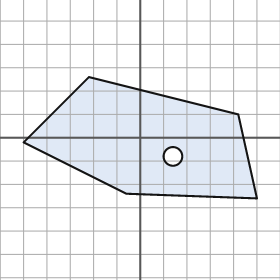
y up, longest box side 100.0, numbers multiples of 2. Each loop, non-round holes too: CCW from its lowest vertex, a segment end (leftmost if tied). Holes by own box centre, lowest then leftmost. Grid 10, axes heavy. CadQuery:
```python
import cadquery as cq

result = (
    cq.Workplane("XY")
    .moveTo(50.0, -26.0)
    .lineTo(42.0, 10.0)
    .lineTo(-22.0, 26.0)
    .lineTo(-50.0, -2.0)
    .lineTo(-6.0, -24.0)
    .close()
    .moveTo(14.0, -8.0)
    .circle(4.0)
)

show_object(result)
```